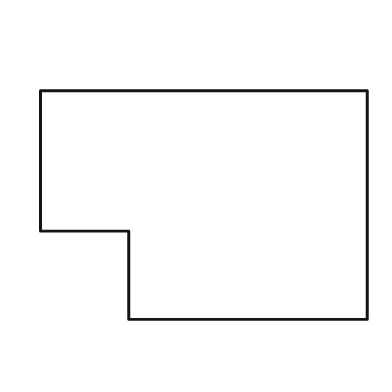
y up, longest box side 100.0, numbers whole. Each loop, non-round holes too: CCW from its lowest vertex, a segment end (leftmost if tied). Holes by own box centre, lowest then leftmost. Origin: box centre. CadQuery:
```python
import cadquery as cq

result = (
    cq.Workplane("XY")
    .moveTo(-23.0, -35.0)
    .lineTo(50.0, -35.0)
    .lineTo(50.0, 35.0)
    .lineTo(-50.0, 35.0)
    .lineTo(-50.0, -8.0)
    .lineTo(-23.0, -8.0)
    .close()
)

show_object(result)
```